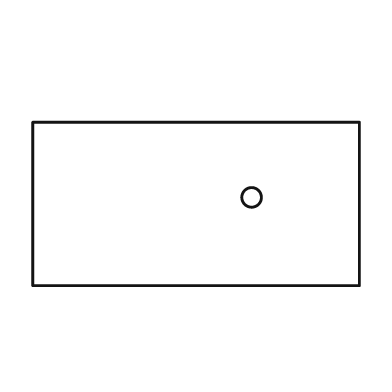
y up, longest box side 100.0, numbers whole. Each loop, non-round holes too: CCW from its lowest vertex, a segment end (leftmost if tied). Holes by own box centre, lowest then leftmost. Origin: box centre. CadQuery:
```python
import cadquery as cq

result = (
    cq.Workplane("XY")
    .moveTo(-50.0, -25.0)
    .lineTo(50.0, -25.0)
    .lineTo(50.0, 25.0)
    .lineTo(-50.0, 25.0)
    .close()
    .moveTo(17.0, 2.0)
    .circle(3.0)
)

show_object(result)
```